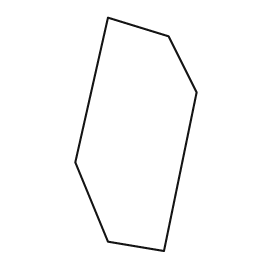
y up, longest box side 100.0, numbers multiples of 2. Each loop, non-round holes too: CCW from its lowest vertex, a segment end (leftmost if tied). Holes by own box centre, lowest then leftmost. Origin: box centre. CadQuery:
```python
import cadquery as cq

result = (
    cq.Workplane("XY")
    .moveTo(12.0, -50.0)
    .lineTo(26.0, 18.0)
    .lineTo(14.0, 42.0)
    .lineTo(-12.0, 50.0)
    .lineTo(-26.0, -12.0)
    .lineTo(-12.0, -46.0)
    .close()
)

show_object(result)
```